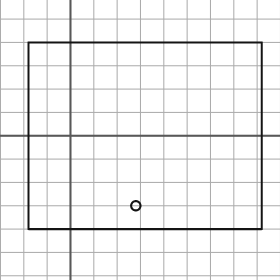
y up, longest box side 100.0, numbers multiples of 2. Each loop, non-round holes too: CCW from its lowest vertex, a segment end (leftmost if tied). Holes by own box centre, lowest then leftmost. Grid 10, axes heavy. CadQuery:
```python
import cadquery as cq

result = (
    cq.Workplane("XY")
    .moveTo(-18.0, -40.0)
    .lineTo(82.0, -40.0)
    .lineTo(82.0, 40.0)
    .lineTo(-18.0, 40.0)
    .close()
    .moveTo(28.0, -30.0)
    .circle(2.0)
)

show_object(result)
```